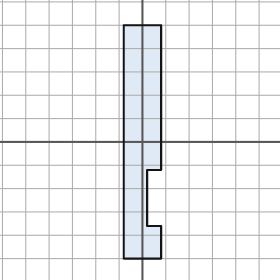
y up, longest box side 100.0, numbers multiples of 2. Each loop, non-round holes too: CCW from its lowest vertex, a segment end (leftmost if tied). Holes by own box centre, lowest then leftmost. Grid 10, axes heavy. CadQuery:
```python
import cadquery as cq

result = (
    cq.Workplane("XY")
    .moveTo(-8.0, -50.0)
    .lineTo(8.0, -50.0)
    .lineTo(8.0, -36.0)
    .lineTo(2.0, -36.0)
    .lineTo(2.0, -12.0)
    .lineTo(8.0, -12.0)
    .lineTo(8.0, 50.0)
    .lineTo(-8.0, 50.0)
    .close()
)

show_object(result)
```